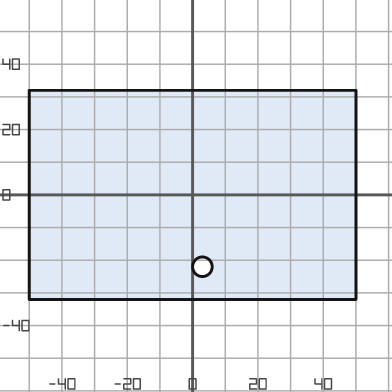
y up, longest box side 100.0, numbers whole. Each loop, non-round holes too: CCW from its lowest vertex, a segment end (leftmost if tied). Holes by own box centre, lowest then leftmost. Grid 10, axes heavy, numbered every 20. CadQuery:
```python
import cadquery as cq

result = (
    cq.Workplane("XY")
    .moveTo(-50.0, -32.0)
    .lineTo(50.0, -32.0)
    .lineTo(50.0, 32.0)
    .lineTo(-50.0, 32.0)
    .close()
    .moveTo(3.0, -22.0)
    .circle(3.0)
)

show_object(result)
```